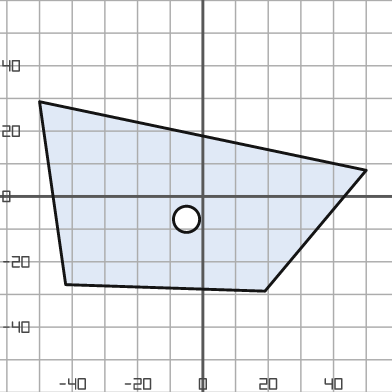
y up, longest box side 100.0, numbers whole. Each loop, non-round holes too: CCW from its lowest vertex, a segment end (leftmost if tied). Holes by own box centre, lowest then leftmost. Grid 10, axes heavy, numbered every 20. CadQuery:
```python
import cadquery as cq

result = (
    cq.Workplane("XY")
    .moveTo(19.0, -29.0)
    .lineTo(50.0, 8.0)
    .lineTo(-50.0, 29.0)
    .lineTo(-42.0, -27.0)
    .close()
    .moveTo(-5.0, -7.0)
    .circle(4.0)
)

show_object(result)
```